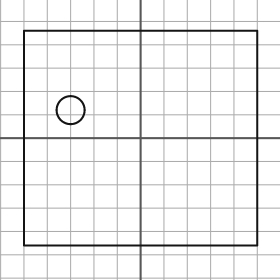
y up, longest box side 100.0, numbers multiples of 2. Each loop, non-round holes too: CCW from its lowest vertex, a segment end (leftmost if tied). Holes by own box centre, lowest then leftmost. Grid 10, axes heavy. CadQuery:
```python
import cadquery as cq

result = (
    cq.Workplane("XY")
    .moveTo(-50.0, -46.0)
    .lineTo(50.0, -46.0)
    .lineTo(50.0, 46.0)
    .lineTo(-50.0, 46.0)
    .close()
    .moveTo(-30.0, 12.0)
    .circle(6.0)
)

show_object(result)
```